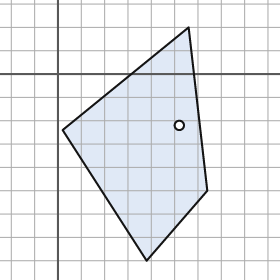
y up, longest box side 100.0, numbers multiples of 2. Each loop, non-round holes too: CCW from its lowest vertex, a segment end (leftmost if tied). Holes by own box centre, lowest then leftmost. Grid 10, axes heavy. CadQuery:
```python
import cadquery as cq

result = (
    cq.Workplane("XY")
    .moveTo(38.0, -80.0)
    .lineTo(64.0, -50.0)
    .lineTo(56.0, 20.0)
    .lineTo(2.0, -24.0)
    .close()
    .moveTo(52.0, -22.0)
    .circle(2.0)
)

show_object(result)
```